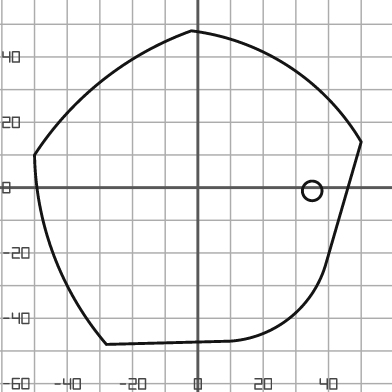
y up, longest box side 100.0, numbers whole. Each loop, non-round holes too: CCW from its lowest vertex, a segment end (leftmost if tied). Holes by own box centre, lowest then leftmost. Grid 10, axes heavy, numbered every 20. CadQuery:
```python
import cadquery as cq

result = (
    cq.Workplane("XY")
    .moveTo(-28.0, -48.0)
    .lineTo(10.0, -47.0)
    .threePointArc((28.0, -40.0), (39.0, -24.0))
    .lineTo(50.0, 14.0)
    .threePointArc((28.0, 37.0), (-2.0, 48.0))
    .threePointArc((-29.0, 33.0), (-50.0, 10.0))
    .threePointArc((-44.0, -21.0), (-28.0, -48.0))
    .close()
    .moveTo(35.0, -1.0)
    .circle(3.0)
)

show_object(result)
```